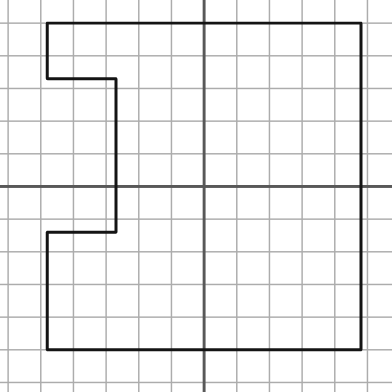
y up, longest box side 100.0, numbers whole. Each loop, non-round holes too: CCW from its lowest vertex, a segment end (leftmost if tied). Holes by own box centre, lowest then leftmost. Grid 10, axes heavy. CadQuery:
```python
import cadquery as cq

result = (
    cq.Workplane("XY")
    .moveTo(-48.0, -50.0)
    .lineTo(48.0, -50.0)
    .lineTo(48.0, 50.0)
    .lineTo(-48.0, 50.0)
    .lineTo(-48.0, 33.0)
    .lineTo(-27.0, 33.0)
    .lineTo(-27.0, -14.0)
    .lineTo(-48.0, -14.0)
    .close()
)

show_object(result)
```